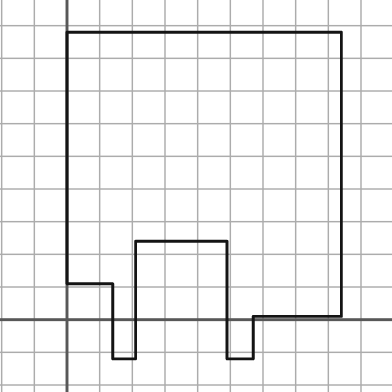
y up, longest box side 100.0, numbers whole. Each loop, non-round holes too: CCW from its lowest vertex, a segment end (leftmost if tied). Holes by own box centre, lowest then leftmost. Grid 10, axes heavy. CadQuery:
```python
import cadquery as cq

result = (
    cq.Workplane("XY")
    .moveTo(14.0, -12.0)
    .lineTo(21.0, -12.0)
    .lineTo(21.0, 24.0)
    .lineTo(49.0, 24.0)
    .lineTo(49.0, -12.0)
    .lineTo(57.0, -12.0)
    .lineTo(57.0, 1.0)
    .lineTo(84.0, 1.0)
    .lineTo(84.0, 88.0)
    .lineTo(0.0, 88.0)
    .lineTo(0.0, 11.0)
    .lineTo(14.0, 11.0)
    .close()
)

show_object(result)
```